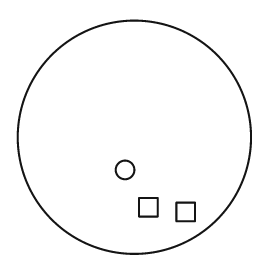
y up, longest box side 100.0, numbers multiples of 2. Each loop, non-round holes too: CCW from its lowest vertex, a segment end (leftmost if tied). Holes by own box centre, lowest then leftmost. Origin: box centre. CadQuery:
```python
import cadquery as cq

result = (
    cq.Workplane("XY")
    .moveTo(0.0, 0.0)
    .circle(50.0)
    .moveTo(18.0, -36.0)
    .lineTo(26.0, -36.0)
    .lineTo(26.0, -28.0)
    .lineTo(18.0, -28.0)
    .close()
    .moveTo(2.0, -34.0)
    .lineTo(10.0, -34.0)
    .lineTo(10.0, -26.0)
    .lineTo(2.0, -26.0)
    .close()
    .moveTo(-4.0, -14.0)
    .circle(4.0)
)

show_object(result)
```